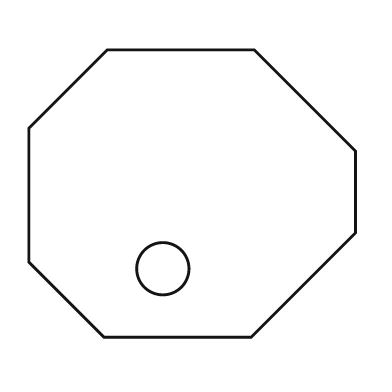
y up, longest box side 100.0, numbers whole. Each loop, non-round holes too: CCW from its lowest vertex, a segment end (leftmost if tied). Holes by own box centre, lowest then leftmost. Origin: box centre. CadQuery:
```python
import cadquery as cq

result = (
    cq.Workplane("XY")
    .moveTo(-27.0, -44.0)
    .lineTo(18.0, -44.0)
    .lineTo(50.0, -12.0)
    .lineTo(50.0, 13.0)
    .lineTo(19.0, 44.0)
    .lineTo(-26.0, 44.0)
    .lineTo(-50.0, 20.0)
    .lineTo(-50.0, -21.0)
    .close()
    .moveTo(-9.0, -23.0)
    .circle(8.0)
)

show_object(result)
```